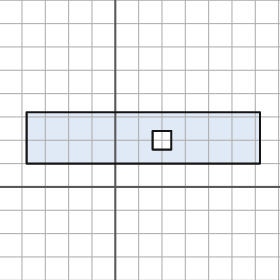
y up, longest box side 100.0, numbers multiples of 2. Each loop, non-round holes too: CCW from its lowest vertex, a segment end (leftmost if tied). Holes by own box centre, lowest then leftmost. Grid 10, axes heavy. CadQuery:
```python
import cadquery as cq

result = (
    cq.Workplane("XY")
    .moveTo(-38.0, 10.0)
    .lineTo(62.0, 10.0)
    .lineTo(62.0, 32.0)
    .lineTo(-38.0, 32.0)
    .close()
    .moveTo(16.0, 16.0)
    .lineTo(24.0, 16.0)
    .lineTo(24.0, 24.0)
    .lineTo(16.0, 24.0)
    .close()
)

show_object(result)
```